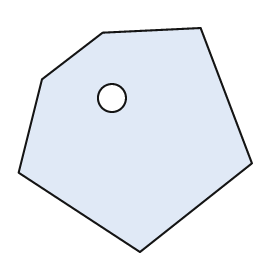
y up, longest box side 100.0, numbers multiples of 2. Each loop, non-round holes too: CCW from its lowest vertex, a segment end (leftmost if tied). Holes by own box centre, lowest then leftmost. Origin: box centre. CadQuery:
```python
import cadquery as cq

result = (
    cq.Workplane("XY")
    .moveTo(2.0, -48.0)
    .lineTo(50.0, -10.0)
    .lineTo(28.0, 48.0)
    .lineTo(-14.0, 46.0)
    .lineTo(-40.0, 26.0)
    .lineTo(-50.0, -14.0)
    .close()
    .moveTo(-10.0, 18.0)
    .circle(6.0)
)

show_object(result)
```